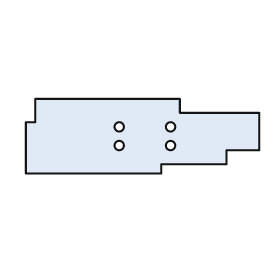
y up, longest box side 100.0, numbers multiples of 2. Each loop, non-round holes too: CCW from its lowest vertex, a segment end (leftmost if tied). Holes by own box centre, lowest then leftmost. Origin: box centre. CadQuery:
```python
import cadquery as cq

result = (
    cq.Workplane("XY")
    .moveTo(-50.0, -16.0)
    .lineTo(8.0, -16.0)
    .lineTo(8.0, -12.0)
    .lineTo(36.0, -12.0)
    .lineTo(36.0, -6.0)
    .lineTo(50.0, -6.0)
    .lineTo(50.0, 10.0)
    .lineTo(16.0, 10.0)
    .lineTo(16.0, 16.0)
    .lineTo(-46.0, 16.0)
    .lineTo(-46.0, 6.0)
    .lineTo(-50.0, 6.0)
    .close()
    .moveTo(-10.0, -4.0)
    .circle(2.0)
    .moveTo(12.0, -4.0)
    .circle(2.0)
    .moveTo(-10.0, 4.0)
    .circle(2.0)
    .moveTo(12.0, 4.0)
    .circle(2.0)
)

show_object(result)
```